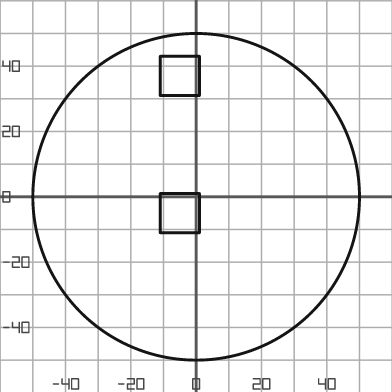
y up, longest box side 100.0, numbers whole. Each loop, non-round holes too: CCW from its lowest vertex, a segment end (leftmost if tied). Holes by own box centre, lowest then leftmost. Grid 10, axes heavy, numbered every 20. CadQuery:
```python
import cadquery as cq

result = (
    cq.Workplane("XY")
    .moveTo(0.0, 0.0)
    .circle(50.0)
    .moveTo(-11.0, -11.0)
    .lineTo(1.0, -11.0)
    .lineTo(1.0, 1.0)
    .lineTo(-11.0, 1.0)
    .close()
    .moveTo(-11.0, 31.0)
    .lineTo(1.0, 31.0)
    .lineTo(1.0, 43.0)
    .lineTo(-11.0, 43.0)
    .close()
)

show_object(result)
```